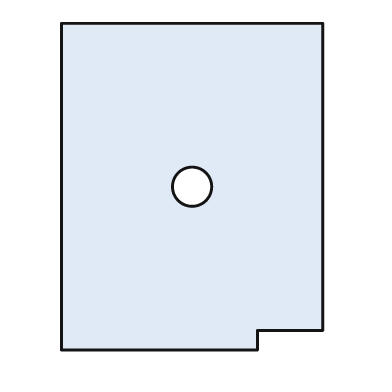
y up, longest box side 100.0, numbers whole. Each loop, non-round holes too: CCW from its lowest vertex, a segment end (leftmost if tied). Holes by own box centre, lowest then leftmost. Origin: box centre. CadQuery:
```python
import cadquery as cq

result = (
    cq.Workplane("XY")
    .moveTo(-40.0, -50.0)
    .lineTo(20.0, -50.0)
    .lineTo(20.0, -44.0)
    .lineTo(40.0, -44.0)
    .lineTo(40.0, 50.0)
    .lineTo(-40.0, 50.0)
    .close()
    .moveTo(0.0, 0.0)
    .circle(6.0)
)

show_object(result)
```